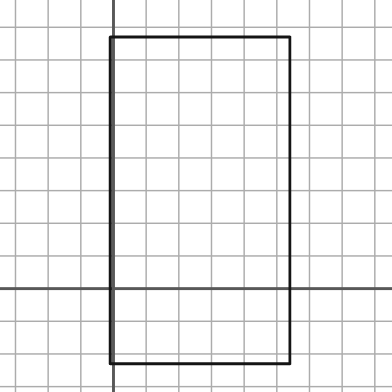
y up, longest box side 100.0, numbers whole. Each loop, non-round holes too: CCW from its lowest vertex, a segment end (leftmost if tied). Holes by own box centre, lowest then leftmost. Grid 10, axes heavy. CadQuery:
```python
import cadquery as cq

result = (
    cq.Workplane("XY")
    .moveTo(-1.0, -23.0)
    .lineTo(54.0, -23.0)
    .lineTo(54.0, 77.0)
    .lineTo(-1.0, 77.0)
    .close()
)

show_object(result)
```